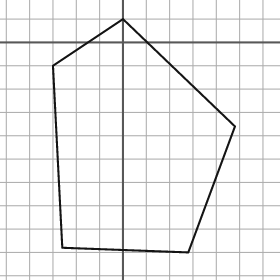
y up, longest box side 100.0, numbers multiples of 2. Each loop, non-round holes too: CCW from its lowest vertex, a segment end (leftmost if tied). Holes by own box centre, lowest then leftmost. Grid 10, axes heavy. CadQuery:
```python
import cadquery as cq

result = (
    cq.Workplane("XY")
    .moveTo(28.0, -90.0)
    .lineTo(48.0, -36.0)
    .lineTo(0.0, 10.0)
    .lineTo(-30.0, -10.0)
    .lineTo(-26.0, -88.0)
    .close()
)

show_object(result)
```